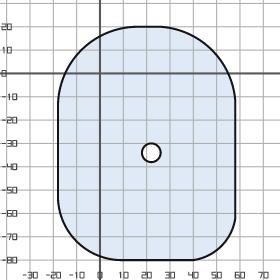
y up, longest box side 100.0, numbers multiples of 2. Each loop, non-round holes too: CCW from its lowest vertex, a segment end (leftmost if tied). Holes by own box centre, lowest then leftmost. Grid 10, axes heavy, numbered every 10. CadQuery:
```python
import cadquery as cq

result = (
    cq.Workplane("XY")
    .moveTo(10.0, -80.0)
    .lineTo(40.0, -80.0)
    .threePointArc((52.0, -74.0), (58.0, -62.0))
    .lineTo(58.0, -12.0)
    .threePointArc((48.0, 10.0), (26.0, 20.0))
    .lineTo(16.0, 20.0)
    .threePointArc((-8.0, 10.0), (-18.0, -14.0))
    .lineTo(-18.0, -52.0)
    .threePointArc((-10.0, -72.0), (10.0, -80.0))
    .close()
    .moveTo(22.0, -34.0)
    .circle(4.0)
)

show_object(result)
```